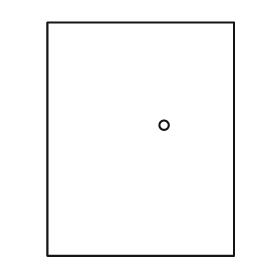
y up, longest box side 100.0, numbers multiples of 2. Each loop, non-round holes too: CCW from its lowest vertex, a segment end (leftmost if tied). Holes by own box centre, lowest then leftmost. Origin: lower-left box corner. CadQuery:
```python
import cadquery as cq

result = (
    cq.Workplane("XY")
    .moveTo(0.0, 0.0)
    .lineTo(80.0, 0.0)
    .lineTo(80.0, 100.0)
    .lineTo(0.0, 100.0)
    .close()
    .moveTo(50.0, 56.0)
    .circle(2.0)
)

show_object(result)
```